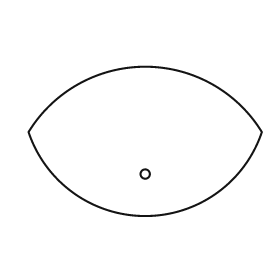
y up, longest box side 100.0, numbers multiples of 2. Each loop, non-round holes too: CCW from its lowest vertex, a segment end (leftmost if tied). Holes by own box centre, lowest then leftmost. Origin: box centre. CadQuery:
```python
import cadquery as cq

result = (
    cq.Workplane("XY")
    .moveTo(-50.0, 4.0)
    .threePointArc((0.0, -32.0), (50.0, 4.0))
    .threePointArc((0.0, 32.0), (-50.0, 4.0))
    .close()
    .moveTo(0.0, -14.0)
    .circle(2.0)
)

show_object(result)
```